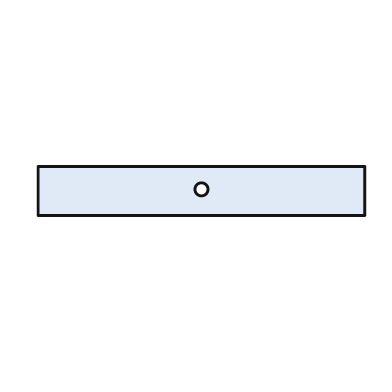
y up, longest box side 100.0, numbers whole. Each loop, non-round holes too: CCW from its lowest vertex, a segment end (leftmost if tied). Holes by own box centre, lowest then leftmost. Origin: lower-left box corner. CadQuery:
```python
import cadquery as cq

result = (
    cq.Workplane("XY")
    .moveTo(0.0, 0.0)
    .lineTo(100.0, 0.0)
    .lineTo(100.0, 15.0)
    .lineTo(0.0, 15.0)
    .close()
    .moveTo(50.0, 8.0)
    .circle(2.0)
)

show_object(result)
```